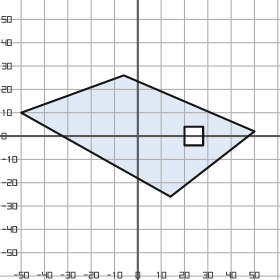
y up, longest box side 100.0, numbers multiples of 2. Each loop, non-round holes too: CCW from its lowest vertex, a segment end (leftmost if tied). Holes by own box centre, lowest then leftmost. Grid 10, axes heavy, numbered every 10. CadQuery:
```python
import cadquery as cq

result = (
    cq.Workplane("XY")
    .moveTo(14.0, -26.0)
    .lineTo(50.0, 2.0)
    .lineTo(-6.0, 26.0)
    .lineTo(-50.0, 10.0)
    .close()
    .moveTo(20.0, -4.0)
    .lineTo(28.0, -4.0)
    .lineTo(28.0, 4.0)
    .lineTo(20.0, 4.0)
    .close()
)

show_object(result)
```